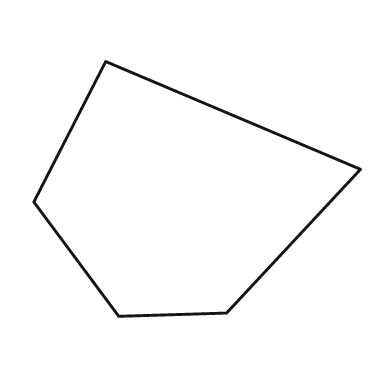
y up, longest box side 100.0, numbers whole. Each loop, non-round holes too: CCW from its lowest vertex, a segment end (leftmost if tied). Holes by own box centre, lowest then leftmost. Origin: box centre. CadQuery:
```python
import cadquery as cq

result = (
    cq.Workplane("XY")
    .moveTo(-24.0, -39.0)
    .lineTo(9.0, -38.0)
    .lineTo(50.0, 6.0)
    .lineTo(-28.0, 39.0)
    .lineTo(-50.0, -4.0)
    .close()
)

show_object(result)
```